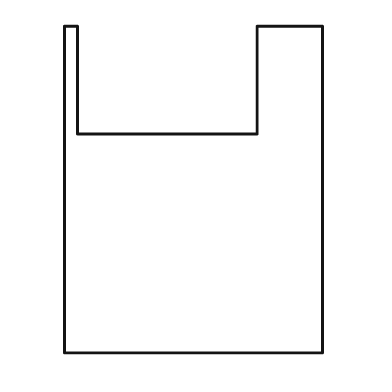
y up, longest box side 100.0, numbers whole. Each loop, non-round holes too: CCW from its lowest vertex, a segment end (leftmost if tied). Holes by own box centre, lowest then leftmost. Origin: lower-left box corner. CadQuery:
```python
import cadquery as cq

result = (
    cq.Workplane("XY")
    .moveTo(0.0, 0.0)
    .lineTo(79.0, 0.0)
    .lineTo(79.0, 100.0)
    .lineTo(59.0, 100.0)
    .lineTo(59.0, 67.0)
    .lineTo(4.0, 67.0)
    .lineTo(4.0, 100.0)
    .lineTo(0.0, 100.0)
    .close()
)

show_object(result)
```